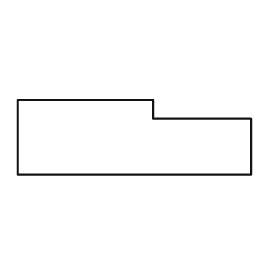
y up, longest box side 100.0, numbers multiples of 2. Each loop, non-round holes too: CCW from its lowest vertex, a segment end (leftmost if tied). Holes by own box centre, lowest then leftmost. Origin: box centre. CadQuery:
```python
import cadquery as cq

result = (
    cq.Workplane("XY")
    .moveTo(-50.0, -16.0)
    .lineTo(50.0, -16.0)
    .lineTo(50.0, 8.0)
    .lineTo(8.0, 8.0)
    .lineTo(8.0, 16.0)
    .lineTo(-50.0, 16.0)
    .close()
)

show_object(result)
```